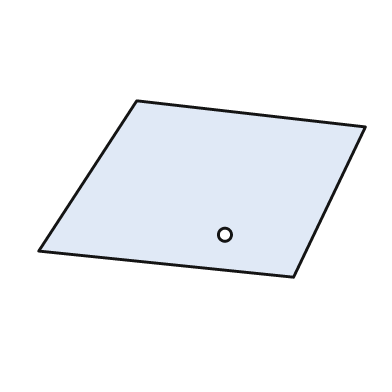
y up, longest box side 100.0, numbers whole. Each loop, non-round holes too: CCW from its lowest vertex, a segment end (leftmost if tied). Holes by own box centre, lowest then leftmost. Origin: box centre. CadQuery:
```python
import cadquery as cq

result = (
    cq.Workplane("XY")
    .moveTo(28.0, -27.0)
    .lineTo(50.0, 19.0)
    .lineTo(-20.0, 27.0)
    .lineTo(-50.0, -19.0)
    .close()
    .moveTo(7.0, -14.0)
    .circle(2.0)
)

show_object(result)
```